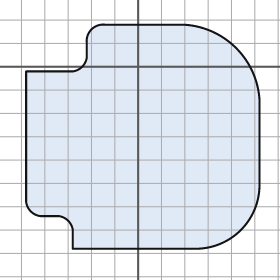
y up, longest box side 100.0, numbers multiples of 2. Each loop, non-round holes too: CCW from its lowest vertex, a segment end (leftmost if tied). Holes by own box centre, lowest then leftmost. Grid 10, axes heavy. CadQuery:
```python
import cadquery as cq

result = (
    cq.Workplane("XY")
    .moveTo(-28.0, -78.0)
    .lineTo(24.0, -78.0)
    .threePointArc((44.0, -70.0), (52.0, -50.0))
    .lineTo(52.0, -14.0)
    .threePointArc((42.0, 8.0), (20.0, 18.0))
    .lineTo(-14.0, 18.0)
    .threePointArc((-20.0, 16.0), (-22.0, 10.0))
    .lineTo(-22.0, 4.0)
    .threePointArc((-24.0, 0.0), (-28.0, -2.0))
    .lineTo(-48.0, -2.0)
    .lineTo(-48.0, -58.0)
    .threePointArc((-46.0, -62.0), (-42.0, -64.0))
    .lineTo(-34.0, -64.0)
    .threePointArc((-30.0, -66.0), (-28.0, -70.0))
    .close()
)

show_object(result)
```